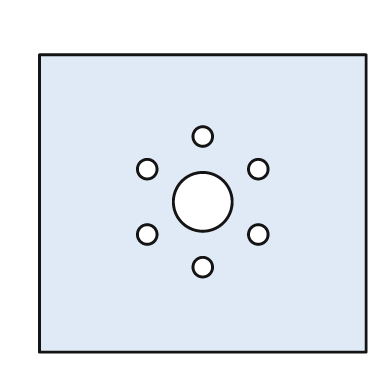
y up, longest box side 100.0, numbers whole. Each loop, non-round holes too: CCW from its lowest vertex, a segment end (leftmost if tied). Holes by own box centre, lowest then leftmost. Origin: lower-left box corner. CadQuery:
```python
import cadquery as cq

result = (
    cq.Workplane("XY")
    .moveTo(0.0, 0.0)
    .lineTo(100.0, 0.0)
    .lineTo(100.0, 91.0)
    .lineTo(0.0, 91.0)
    .close()
    .moveTo(50.0, 26.0)
    .circle(3.0)
    .moveTo(33.0, 36.0)
    .circle(3.0)
    .moveTo(67.0, 36.0)
    .circle(3.0)
    .moveTo(50.0, 46.0)
    .circle(9.0)
    .moveTo(33.0, 56.0)
    .circle(3.0)
    .moveTo(67.0, 56.0)
    .circle(3.0)
    .moveTo(50.0, 66.0)
    .circle(3.0)
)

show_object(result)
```